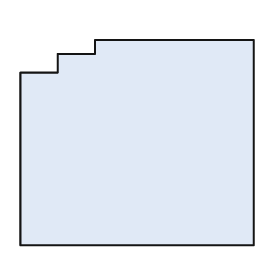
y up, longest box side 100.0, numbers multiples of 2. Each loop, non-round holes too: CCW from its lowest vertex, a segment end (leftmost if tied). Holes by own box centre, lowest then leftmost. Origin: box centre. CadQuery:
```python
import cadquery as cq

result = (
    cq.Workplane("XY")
    .moveTo(-50.0, -44.0)
    .lineTo(50.0, -44.0)
    .lineTo(50.0, 44.0)
    .lineTo(-18.0, 44.0)
    .lineTo(-18.0, 38.0)
    .lineTo(-34.0, 38.0)
    .lineTo(-34.0, 30.0)
    .lineTo(-50.0, 30.0)
    .close()
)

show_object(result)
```